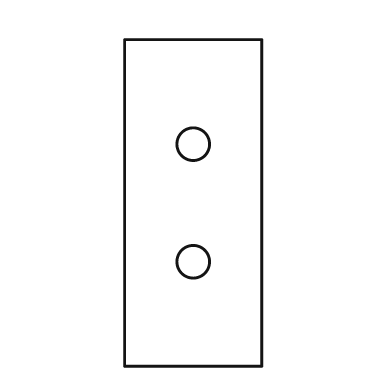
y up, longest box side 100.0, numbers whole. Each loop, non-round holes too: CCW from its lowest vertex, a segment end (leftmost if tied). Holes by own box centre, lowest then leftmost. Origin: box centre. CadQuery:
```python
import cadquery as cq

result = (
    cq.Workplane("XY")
    .moveTo(-21.0, -50.0)
    .lineTo(21.0, -50.0)
    .lineTo(21.0, 50.0)
    .lineTo(-21.0, 50.0)
    .close()
    .moveTo(0.0, -18.0)
    .circle(5.0)
    .moveTo(0.0, 18.0)
    .circle(5.0)
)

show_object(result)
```